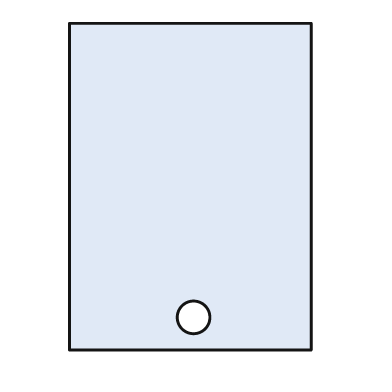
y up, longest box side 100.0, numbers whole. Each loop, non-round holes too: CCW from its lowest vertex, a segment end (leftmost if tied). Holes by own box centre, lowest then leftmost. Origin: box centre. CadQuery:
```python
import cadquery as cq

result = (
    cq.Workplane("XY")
    .moveTo(-37.0, -50.0)
    .lineTo(37.0, -50.0)
    .lineTo(37.0, 50.0)
    .lineTo(-37.0, 50.0)
    .close()
    .moveTo(1.0, -40.0)
    .circle(5.0)
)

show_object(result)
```